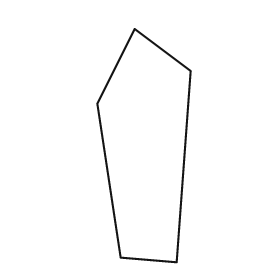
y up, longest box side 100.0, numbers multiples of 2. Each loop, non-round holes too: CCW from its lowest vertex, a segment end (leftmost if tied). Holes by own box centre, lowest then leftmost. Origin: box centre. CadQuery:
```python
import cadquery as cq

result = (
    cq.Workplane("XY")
    .moveTo(14.0, -50.0)
    .lineTo(20.0, 32.0)
    .lineTo(-4.0, 50.0)
    .lineTo(-20.0, 18.0)
    .lineTo(-10.0, -48.0)
    .close()
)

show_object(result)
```